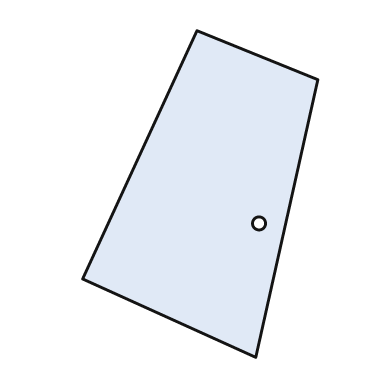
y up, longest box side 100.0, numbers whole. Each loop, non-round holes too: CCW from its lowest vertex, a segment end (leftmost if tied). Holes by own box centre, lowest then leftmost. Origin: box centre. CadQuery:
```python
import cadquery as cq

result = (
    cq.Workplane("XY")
    .moveTo(17.0, -50.0)
    .lineTo(36.0, 35.0)
    .lineTo(-1.0, 50.0)
    .lineTo(-36.0, -26.0)
    .close()
    .moveTo(18.0, -9.0)
    .circle(2.0)
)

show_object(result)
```